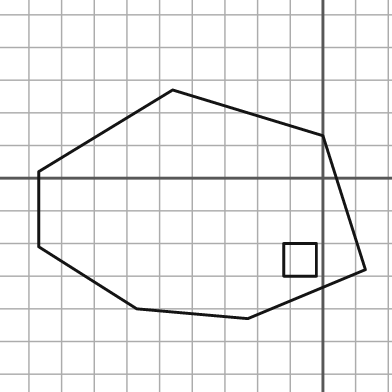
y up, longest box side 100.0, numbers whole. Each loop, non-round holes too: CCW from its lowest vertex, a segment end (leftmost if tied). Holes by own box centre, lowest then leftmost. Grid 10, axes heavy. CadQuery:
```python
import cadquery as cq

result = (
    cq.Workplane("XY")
    .moveTo(-23.0, -43.0)
    .lineTo(13.0, -28.0)
    .lineTo(0.0, 13.0)
    .lineTo(-46.0, 27.0)
    .lineTo(-87.0, 2.0)
    .lineTo(-87.0, -21.0)
    .lineTo(-57.0, -40.0)
    .close()
    .moveTo(-12.0, -30.0)
    .lineTo(-2.0, -30.0)
    .lineTo(-2.0, -20.0)
    .lineTo(-12.0, -20.0)
    .close()
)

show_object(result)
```